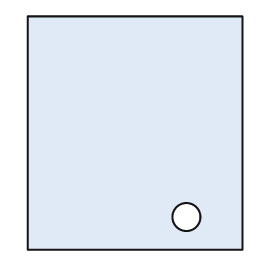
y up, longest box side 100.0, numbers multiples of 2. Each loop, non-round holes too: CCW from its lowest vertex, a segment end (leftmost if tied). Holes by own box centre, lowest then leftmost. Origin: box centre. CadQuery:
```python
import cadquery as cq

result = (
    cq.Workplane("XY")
    .moveTo(-46.0, -50.0)
    .lineTo(46.0, -50.0)
    .lineTo(46.0, 50.0)
    .lineTo(-46.0, 50.0)
    .close()
    .moveTo(22.0, -36.0)
    .circle(6.0)
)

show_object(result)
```